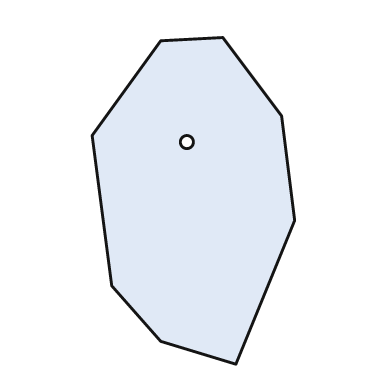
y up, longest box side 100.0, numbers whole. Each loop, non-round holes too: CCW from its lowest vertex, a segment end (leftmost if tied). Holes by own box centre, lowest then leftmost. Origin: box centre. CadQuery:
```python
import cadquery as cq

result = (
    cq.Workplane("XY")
    .moveTo(13.0, -50.0)
    .lineTo(31.0, -6.0)
    .lineTo(27.0, 26.0)
    .lineTo(9.0, 50.0)
    .lineTo(-10.0, 49.0)
    .lineTo(-31.0, 20.0)
    .lineTo(-25.0, -26.0)
    .lineTo(-10.0, -43.0)
    .close()
    .moveTo(-2.0, 18.0)
    .circle(2.0)
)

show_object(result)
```